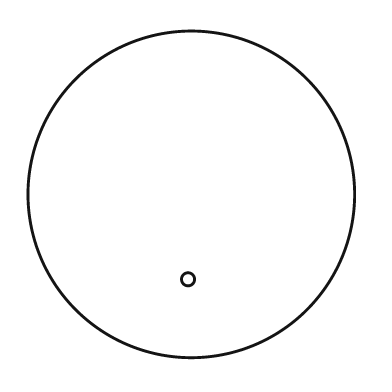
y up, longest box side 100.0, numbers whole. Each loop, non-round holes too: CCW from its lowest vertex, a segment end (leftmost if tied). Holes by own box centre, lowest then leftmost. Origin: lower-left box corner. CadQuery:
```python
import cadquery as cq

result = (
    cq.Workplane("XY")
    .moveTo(50.0, 50.0)
    .circle(50.0)
    .moveTo(49.0, 24.0)
    .circle(2.0)
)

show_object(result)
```